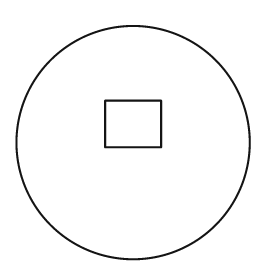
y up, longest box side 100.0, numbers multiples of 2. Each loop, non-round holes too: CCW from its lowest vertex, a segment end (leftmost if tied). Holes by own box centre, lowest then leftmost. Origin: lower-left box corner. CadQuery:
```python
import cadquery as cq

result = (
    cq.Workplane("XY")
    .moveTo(50.0, 50.0)
    .circle(50.0)
    .moveTo(38.0, 48.0)
    .lineTo(62.0, 48.0)
    .lineTo(62.0, 68.0)
    .lineTo(38.0, 68.0)
    .close()
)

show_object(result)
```